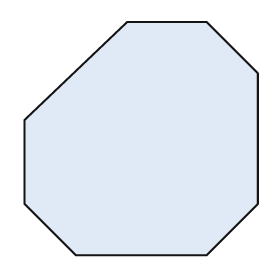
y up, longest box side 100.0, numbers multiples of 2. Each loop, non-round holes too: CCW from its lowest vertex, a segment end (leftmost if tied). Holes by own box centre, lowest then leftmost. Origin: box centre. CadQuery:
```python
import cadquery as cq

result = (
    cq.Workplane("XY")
    .moveTo(-28.0, -50.0)
    .lineTo(28.0, -50.0)
    .lineTo(50.0, -28.0)
    .lineTo(50.0, 28.0)
    .lineTo(28.0, 50.0)
    .lineTo(-6.0, 50.0)
    .lineTo(-50.0, 8.0)
    .lineTo(-50.0, -28.0)
    .close()
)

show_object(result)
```